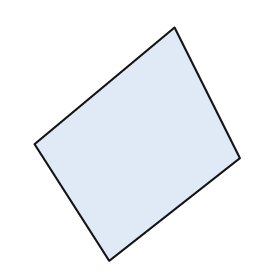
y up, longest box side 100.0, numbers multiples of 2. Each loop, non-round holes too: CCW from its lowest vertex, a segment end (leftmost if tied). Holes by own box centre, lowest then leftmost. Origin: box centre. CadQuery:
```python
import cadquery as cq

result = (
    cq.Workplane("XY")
    .moveTo(-12.0, -50.0)
    .lineTo(44.0, -6.0)
    .lineTo(16.0, 50.0)
    .lineTo(-44.0, 0.0)
    .close()
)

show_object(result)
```